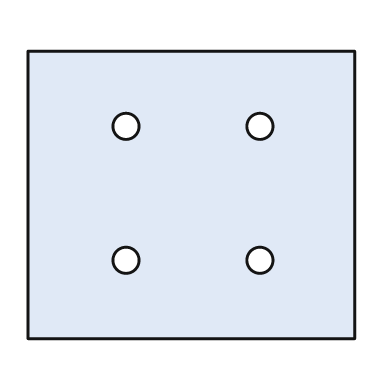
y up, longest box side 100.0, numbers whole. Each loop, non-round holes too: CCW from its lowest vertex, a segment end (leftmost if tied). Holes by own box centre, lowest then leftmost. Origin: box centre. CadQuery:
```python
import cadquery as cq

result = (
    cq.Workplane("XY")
    .moveTo(-50.0, -44.0)
    .lineTo(50.0, -44.0)
    .lineTo(50.0, 44.0)
    .lineTo(-50.0, 44.0)
    .close()
    .moveTo(-20.0, -20.0)
    .circle(4.0)
    .moveTo(21.0, -20.0)
    .circle(4.0)
    .moveTo(-20.0, 21.0)
    .circle(4.0)
    .moveTo(21.0, 21.0)
    .circle(4.0)
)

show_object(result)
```